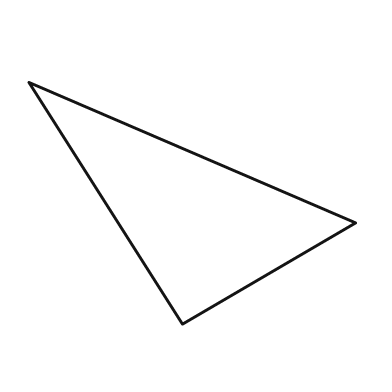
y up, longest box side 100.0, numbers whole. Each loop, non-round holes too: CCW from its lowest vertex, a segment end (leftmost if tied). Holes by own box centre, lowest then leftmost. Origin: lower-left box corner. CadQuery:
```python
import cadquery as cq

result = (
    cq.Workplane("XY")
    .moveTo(47.0, 0.0)
    .lineTo(100.0, 31.0)
    .lineTo(0.0, 74.0)
    .close()
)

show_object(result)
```